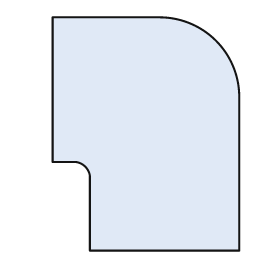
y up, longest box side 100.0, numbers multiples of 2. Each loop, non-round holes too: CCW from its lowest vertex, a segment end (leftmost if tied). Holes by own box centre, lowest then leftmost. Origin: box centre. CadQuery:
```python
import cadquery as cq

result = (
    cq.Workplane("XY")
    .moveTo(-24.0, -50.0)
    .lineTo(40.0, -50.0)
    .lineTo(40.0, 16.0)
    .threePointArc((30.0, 40.0), (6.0, 50.0))
    .lineTo(-40.0, 50.0)
    .lineTo(-40.0, -12.0)
    .lineTo(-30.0, -12.0)
    .threePointArc((-26.0, -14.0), (-24.0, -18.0))
    .close()
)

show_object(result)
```